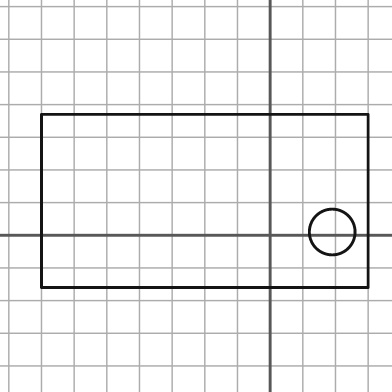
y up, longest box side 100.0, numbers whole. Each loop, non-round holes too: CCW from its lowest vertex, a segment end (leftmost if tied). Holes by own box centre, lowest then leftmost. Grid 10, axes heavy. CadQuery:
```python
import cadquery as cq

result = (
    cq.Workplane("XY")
    .moveTo(-70.0, -16.0)
    .lineTo(30.0, -16.0)
    .lineTo(30.0, 37.0)
    .lineTo(-70.0, 37.0)
    .close()
    .moveTo(19.0, 1.0)
    .circle(7.0)
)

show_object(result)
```